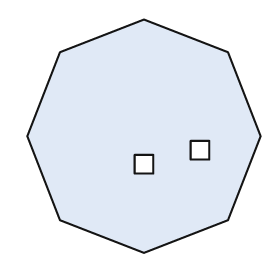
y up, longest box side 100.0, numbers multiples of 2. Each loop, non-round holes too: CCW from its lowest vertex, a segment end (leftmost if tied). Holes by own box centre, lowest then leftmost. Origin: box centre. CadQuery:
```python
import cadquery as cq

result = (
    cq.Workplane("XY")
    .moveTo(0.0, -50.0)
    .lineTo(36.0, -36.0)
    .lineTo(50.0, 0.0)
    .lineTo(36.0, 36.0)
    .lineTo(0.0, 50.0)
    .lineTo(-36.0, 36.0)
    .lineTo(-50.0, 0.0)
    .lineTo(-36.0, -36.0)
    .close()
    .moveTo(-4.0, -16.0)
    .lineTo(4.0, -16.0)
    .lineTo(4.0, -8.0)
    .lineTo(-4.0, -8.0)
    .close()
    .moveTo(20.0, -10.0)
    .lineTo(28.0, -10.0)
    .lineTo(28.0, -2.0)
    .lineTo(20.0, -2.0)
    .close()
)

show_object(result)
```